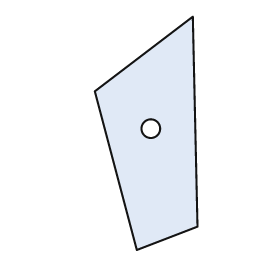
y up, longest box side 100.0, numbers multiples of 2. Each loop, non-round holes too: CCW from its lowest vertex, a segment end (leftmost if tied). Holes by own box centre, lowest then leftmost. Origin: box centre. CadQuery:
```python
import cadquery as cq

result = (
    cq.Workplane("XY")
    .moveTo(-4.0, -50.0)
    .lineTo(22.0, -40.0)
    .lineTo(20.0, 50.0)
    .lineTo(-22.0, 18.0)
    .close()
    .moveTo(2.0, 2.0)
    .circle(4.0)
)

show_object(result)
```